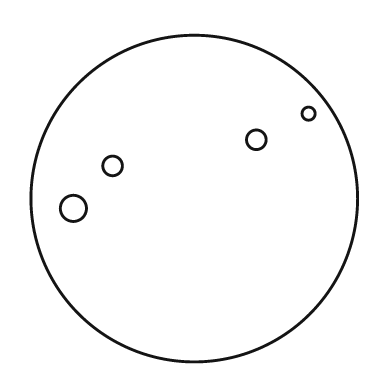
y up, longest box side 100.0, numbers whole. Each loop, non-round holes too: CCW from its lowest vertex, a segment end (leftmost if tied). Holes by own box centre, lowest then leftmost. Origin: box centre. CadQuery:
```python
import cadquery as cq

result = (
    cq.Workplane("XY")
    .moveTo(0.0, 0.0)
    .circle(50.0)
    .moveTo(-37.0, -3.0)
    .circle(4.0)
    .moveTo(-25.0, 10.0)
    .circle(3.0)
    .moveTo(19.0, 18.0)
    .circle(3.0)
    .moveTo(35.0, 26.0)
    .circle(2.0)
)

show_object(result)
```